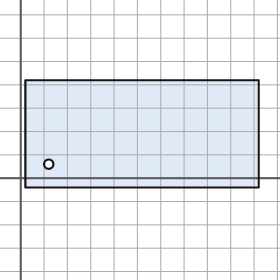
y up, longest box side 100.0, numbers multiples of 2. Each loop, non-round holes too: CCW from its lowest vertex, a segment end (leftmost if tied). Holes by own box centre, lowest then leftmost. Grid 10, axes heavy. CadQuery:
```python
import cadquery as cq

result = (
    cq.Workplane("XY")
    .moveTo(2.0, -4.0)
    .lineTo(102.0, -4.0)
    .lineTo(102.0, 42.0)
    .lineTo(2.0, 42.0)
    .close()
    .moveTo(12.0, 6.0)
    .circle(2.0)
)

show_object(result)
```